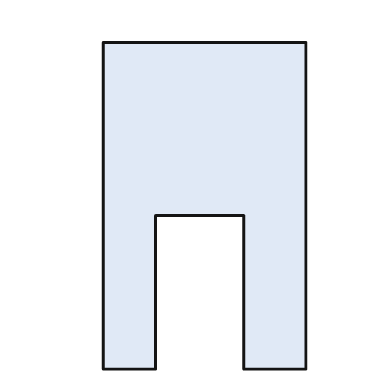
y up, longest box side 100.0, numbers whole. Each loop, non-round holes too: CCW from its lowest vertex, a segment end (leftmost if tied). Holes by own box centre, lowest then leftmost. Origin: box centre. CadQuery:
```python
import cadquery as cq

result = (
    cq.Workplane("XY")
    .moveTo(-31.0, -50.0)
    .lineTo(-15.0, -50.0)
    .lineTo(-15.0, -3.0)
    .lineTo(12.0, -3.0)
    .lineTo(12.0, -50.0)
    .lineTo(31.0, -50.0)
    .lineTo(31.0, 50.0)
    .lineTo(-31.0, 50.0)
    .close()
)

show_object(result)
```